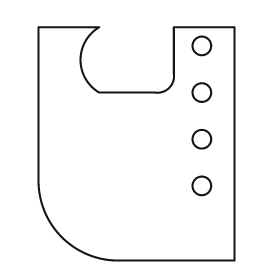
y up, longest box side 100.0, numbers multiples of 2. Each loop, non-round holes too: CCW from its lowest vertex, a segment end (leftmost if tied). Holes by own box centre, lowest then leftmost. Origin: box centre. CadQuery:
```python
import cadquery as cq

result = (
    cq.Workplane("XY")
    .moveTo(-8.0, -50.0)
    .lineTo(42.0, -50.0)
    .lineTo(42.0, 50.0)
    .lineTo(16.0, 50.0)
    .lineTo(16.0, 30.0)
    .threePointArc((14.0, 24.0), (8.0, 22.0))
    .lineTo(-16.0, 22.0)
    .threePointArc((-24.0, 36.0), (-16.0, 50.0))
    .lineTo(-42.0, 50.0)
    .lineTo(-42.0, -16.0)
    .threePointArc((-32.0, -40.0), (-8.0, -50.0))
    .close()
    .moveTo(28.0, -18.0)
    .circle(4.0)
    .moveTo(28.0, 2.0)
    .circle(4.0)
    .moveTo(28.0, 22.0)
    .circle(4.0)
    .moveTo(28.0, 42.0)
    .circle(4.0)
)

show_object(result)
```